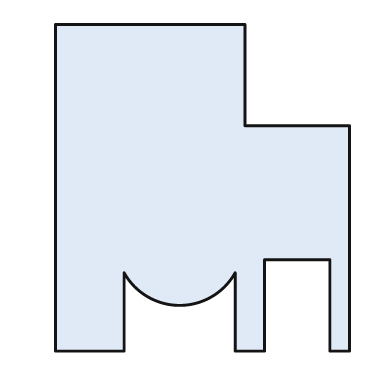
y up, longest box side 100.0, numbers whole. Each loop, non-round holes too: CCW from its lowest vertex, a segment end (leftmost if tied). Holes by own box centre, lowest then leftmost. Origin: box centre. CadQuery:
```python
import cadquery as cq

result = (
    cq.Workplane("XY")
    .moveTo(-45.0, -50.0)
    .lineTo(-24.0, -50.0)
    .lineTo(-24.0, -26.0)
    .threePointArc((-7.0, -36.0), (10.0, -26.0))
    .lineTo(10.0, -50.0)
    .lineTo(19.0, -50.0)
    .lineTo(19.0, -22.0)
    .lineTo(39.0, -22.0)
    .lineTo(39.0, -50.0)
    .lineTo(45.0, -50.0)
    .lineTo(45.0, 19.0)
    .lineTo(13.0, 19.0)
    .lineTo(13.0, 50.0)
    .lineTo(-45.0, 50.0)
    .close()
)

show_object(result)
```